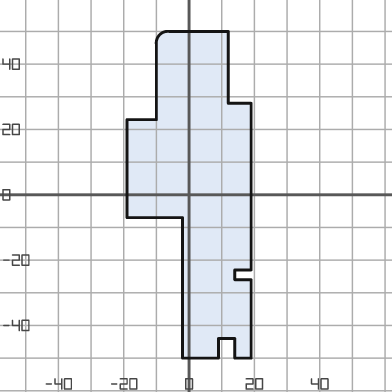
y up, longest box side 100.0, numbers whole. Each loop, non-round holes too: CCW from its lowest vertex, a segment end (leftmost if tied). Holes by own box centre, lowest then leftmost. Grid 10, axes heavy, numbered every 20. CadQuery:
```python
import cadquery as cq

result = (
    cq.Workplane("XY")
    .moveTo(-2.0, -50.0)
    .lineTo(9.0, -50.0)
    .lineTo(9.0, -44.0)
    .lineTo(14.0, -44.0)
    .lineTo(14.0, -50.0)
    .lineTo(19.0, -50.0)
    .lineTo(19.0, -26.0)
    .lineTo(14.0, -26.0)
    .lineTo(14.0, -23.0)
    .lineTo(19.0, -23.0)
    .lineTo(19.0, 28.0)
    .lineTo(12.0, 28.0)
    .lineTo(12.0, 50.0)
    .lineTo(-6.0, 50.0)
    .threePointArc((-9.0, 49.0), (-10.0, 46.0))
    .lineTo(-10.0, 23.0)
    .lineTo(-19.0, 23.0)
    .lineTo(-19.0, -7.0)
    .lineTo(-2.0, -7.0)
    .close()
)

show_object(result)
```